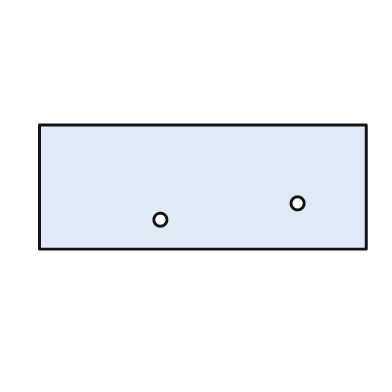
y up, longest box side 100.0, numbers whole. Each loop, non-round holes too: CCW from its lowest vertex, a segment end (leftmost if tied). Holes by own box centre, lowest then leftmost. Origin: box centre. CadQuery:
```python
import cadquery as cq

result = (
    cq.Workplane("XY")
    .moveTo(-50.0, -19.0)
    .lineTo(50.0, -19.0)
    .lineTo(50.0, 19.0)
    .lineTo(-50.0, 19.0)
    .close()
    .moveTo(-13.0, -10.0)
    .circle(2.0)
    .moveTo(29.0, -5.0)
    .circle(2.0)
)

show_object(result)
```